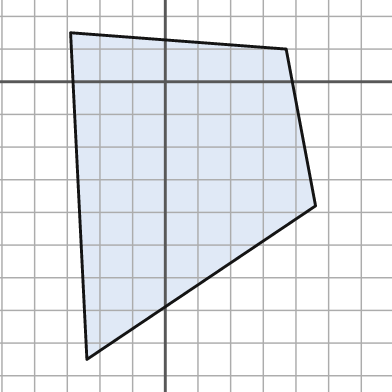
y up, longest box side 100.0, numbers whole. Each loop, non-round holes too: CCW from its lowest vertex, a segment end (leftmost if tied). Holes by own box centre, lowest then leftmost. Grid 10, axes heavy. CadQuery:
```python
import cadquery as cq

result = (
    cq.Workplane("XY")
    .moveTo(-24.0, -85.0)
    .lineTo(46.0, -38.0)
    .lineTo(37.0, 10.0)
    .lineTo(-29.0, 15.0)
    .close()
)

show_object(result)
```